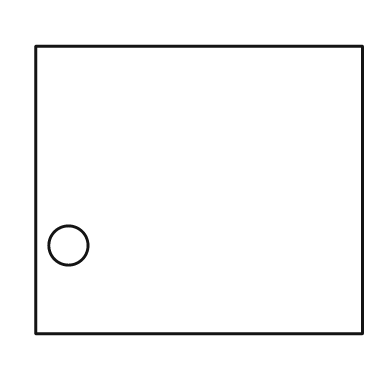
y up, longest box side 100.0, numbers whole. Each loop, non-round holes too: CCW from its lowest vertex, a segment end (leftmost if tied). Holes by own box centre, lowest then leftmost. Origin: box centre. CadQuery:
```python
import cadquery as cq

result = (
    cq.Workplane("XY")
    .moveTo(-50.0, -44.0)
    .lineTo(50.0, -44.0)
    .lineTo(50.0, 44.0)
    .lineTo(-50.0, 44.0)
    .close()
    .moveTo(-40.0, -17.0)
    .circle(6.0)
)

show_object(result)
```